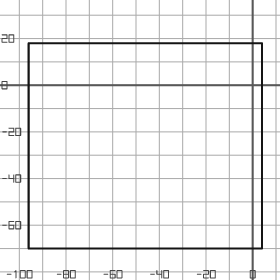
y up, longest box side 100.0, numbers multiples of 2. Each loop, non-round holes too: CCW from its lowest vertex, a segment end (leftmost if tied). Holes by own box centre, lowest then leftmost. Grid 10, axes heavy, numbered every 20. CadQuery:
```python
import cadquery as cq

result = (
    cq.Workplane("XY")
    .moveTo(-96.0, -70.0)
    .lineTo(4.0, -70.0)
    .lineTo(4.0, 18.0)
    .lineTo(-96.0, 18.0)
    .close()
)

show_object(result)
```